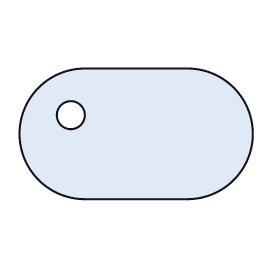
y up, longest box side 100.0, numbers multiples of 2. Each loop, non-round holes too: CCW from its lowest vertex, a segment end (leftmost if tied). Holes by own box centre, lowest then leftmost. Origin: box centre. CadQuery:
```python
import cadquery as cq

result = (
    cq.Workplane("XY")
    .moveTo(-22.0, -28.0)
    .lineTo(22.0, -28.0)
    .threePointArc((50.0, 0.0), (22.0, 28.0))
    .lineTo(-22.0, 28.0)
    .threePointArc((-50.0, 0.0), (-22.0, -28.0))
    .close()
    .moveTo(-28.0, 8.0)
    .circle(6.0)
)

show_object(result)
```